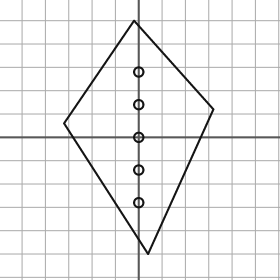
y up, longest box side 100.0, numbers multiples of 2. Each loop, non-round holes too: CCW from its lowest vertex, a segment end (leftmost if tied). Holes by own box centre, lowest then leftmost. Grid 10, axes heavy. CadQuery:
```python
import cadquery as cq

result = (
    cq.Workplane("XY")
    .moveTo(4.0, -50.0)
    .lineTo(32.0, 12.0)
    .lineTo(-2.0, 50.0)
    .lineTo(-32.0, 6.0)
    .close()
    .moveTo(0.0, -28.0)
    .circle(2.0)
    .moveTo(0.0, -14.0)
    .circle(2.0)
    .moveTo(0.0, 0.0)
    .circle(2.0)
    .moveTo(0.0, 14.0)
    .circle(2.0)
    .moveTo(0.0, 28.0)
    .circle(2.0)
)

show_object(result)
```